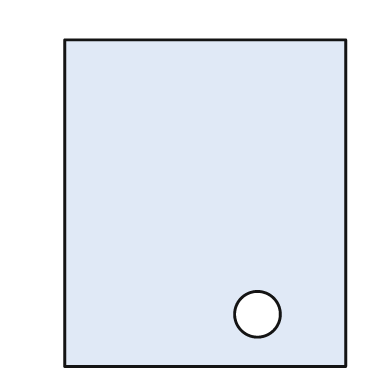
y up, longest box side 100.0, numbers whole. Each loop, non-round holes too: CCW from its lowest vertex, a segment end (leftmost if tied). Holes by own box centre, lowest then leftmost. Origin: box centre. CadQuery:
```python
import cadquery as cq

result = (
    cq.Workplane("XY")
    .moveTo(-43.0, -50.0)
    .lineTo(43.0, -50.0)
    .lineTo(43.0, 50.0)
    .lineTo(-43.0, 50.0)
    .close()
    .moveTo(16.0, -34.0)
    .circle(7.0)
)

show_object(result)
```